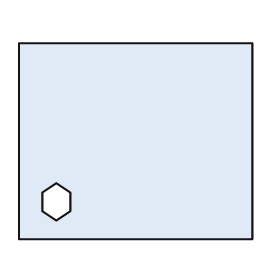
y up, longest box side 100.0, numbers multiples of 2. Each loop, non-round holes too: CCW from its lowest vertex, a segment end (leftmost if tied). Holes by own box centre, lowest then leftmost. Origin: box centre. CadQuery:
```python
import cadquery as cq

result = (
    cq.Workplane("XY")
    .moveTo(-50.0, -42.0)
    .lineTo(50.0, -42.0)
    .lineTo(50.0, 42.0)
    .lineTo(-50.0, 42.0)
    .close()
    .moveTo(-34.0, -34.0)
    .lineTo(-28.0, -30.0)
    .lineTo(-28.0, -22.0)
    .lineTo(-34.0, -18.0)
    .lineTo(-40.0, -22.0)
    .lineTo(-40.0, -30.0)
    .close()
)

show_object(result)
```